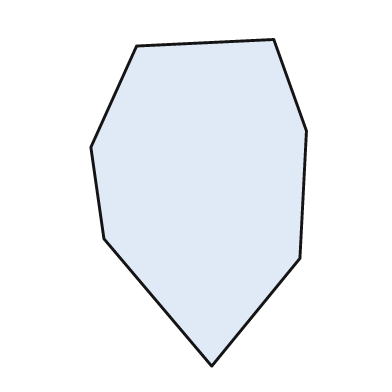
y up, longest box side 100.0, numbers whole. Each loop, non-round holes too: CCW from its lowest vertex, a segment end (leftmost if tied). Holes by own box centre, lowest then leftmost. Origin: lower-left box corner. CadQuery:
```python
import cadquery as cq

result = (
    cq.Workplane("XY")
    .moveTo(37.0, 0.0)
    .lineTo(64.0, 33.0)
    .lineTo(66.0, 72.0)
    .lineTo(56.0, 100.0)
    .lineTo(14.0, 98.0)
    .lineTo(0.0, 67.0)
    .lineTo(4.0, 39.0)
    .close()
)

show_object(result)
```